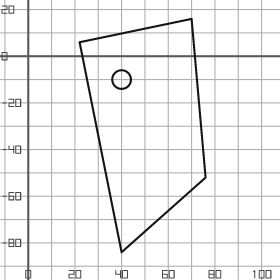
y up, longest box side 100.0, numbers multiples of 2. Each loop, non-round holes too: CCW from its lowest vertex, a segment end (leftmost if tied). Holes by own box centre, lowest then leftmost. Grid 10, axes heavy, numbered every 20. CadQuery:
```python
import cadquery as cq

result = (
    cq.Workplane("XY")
    .moveTo(40.0, -84.0)
    .lineTo(76.0, -52.0)
    .lineTo(70.0, 16.0)
    .lineTo(22.0, 6.0)
    .close()
    .moveTo(40.0, -10.0)
    .circle(4.0)
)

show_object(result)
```